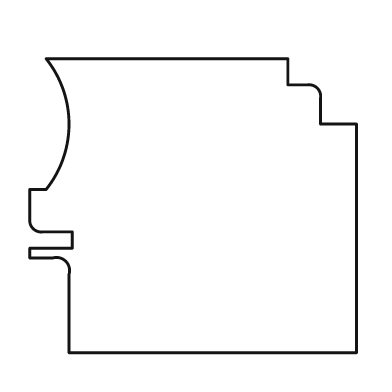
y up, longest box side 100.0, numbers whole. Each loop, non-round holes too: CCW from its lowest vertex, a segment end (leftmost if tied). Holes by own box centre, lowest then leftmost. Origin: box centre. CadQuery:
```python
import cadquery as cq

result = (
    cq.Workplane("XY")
    .moveTo(-38.0, -45.0)
    .lineTo(50.0, -45.0)
    .lineTo(50.0, 25.0)
    .lineTo(39.0, 25.0)
    .lineTo(39.0, 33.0)
    .threePointArc((38.0, 36.0), (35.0, 37.0))
    .lineTo(29.0, 37.0)
    .lineTo(29.0, 45.0)
    .lineTo(-45.0, 45.0)
    .threePointArc((-38.0, 25.0), (-45.0, 5.0))
    .lineTo(-50.0, 5.0)
    .lineTo(-50.0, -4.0)
    .threePointArc((-49.0, -7.0), (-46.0, -8.0))
    .lineTo(-37.0, -8.0)
    .lineTo(-37.0, -13.0)
    .lineTo(-50.0, -13.0)
    .lineTo(-50.0, -16.0)
    .lineTo(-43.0, -16.0)
    .threePointArc((-39.0, -17.0), (-38.0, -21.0))
    .close()
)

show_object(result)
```